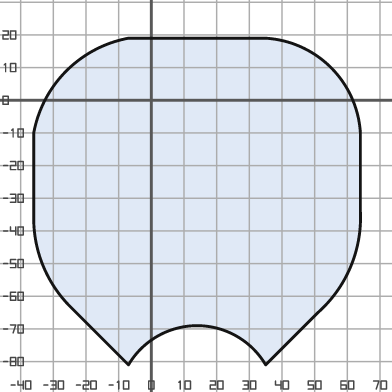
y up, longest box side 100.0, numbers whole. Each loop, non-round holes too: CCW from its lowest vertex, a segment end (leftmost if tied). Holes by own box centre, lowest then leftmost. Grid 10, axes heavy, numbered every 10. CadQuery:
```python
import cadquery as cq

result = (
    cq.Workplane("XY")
    .moveTo(-7.0, -81.0)
    .threePointArc((14.0, -69.0), (35.0, -81.0))
    .lineTo(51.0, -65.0)
    .threePointArc((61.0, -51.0), (64.0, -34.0))
    .lineTo(64.0, -10.0)
    .threePointArc((55.0, 10.0), (35.0, 19.0))
    .lineTo(-7.0, 19.0)
    .threePointArc((-26.0, 9.0), (-36.0, -10.0))
    .lineTo(-36.0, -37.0)
    .threePointArc((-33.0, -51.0), (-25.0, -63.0))
    .close()
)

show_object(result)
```